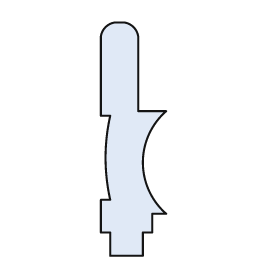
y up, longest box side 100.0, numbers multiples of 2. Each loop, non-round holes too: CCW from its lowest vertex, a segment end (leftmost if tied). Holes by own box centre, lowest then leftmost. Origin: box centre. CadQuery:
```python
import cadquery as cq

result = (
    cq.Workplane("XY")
    .moveTo(-10.0, -50.0)
    .lineTo(4.0, -50.0)
    .lineTo(4.0, -40.0)
    .lineTo(8.0, -40.0)
    .lineTo(8.0, -32.0)
    .lineTo(14.0, -32.0)
    .threePointArc((4.0, -10.0), (14.0, 12.0))
    .lineTo(2.0, 12.0)
    .lineTo(2.0, 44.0)
    .threePointArc((0.0, 48.0), (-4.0, 50.0))
    .lineTo(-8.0, 50.0)
    .threePointArc((-12.0, 48.0), (-14.0, 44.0))
    .lineTo(-14.0, 10.0)
    .lineTo(-10.0, 10.0)
    .threePointArc((-12.0, -8.0), (-10.0, -26.0))
    .lineTo(-14.0, -26.0)
    .lineTo(-14.0, -40.0)
    .lineTo(-10.0, -40.0)
    .close()
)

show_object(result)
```